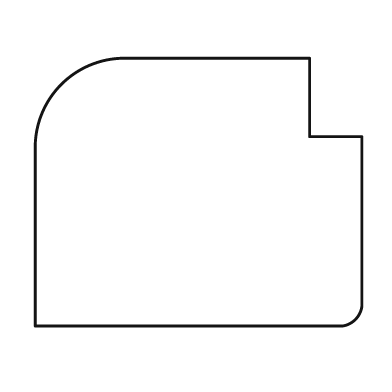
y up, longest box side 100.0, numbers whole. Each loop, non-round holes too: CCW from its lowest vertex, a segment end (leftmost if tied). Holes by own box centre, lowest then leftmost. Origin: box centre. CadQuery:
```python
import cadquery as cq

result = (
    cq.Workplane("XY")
    .moveTo(-50.0, -41.0)
    .lineTo(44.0, -41.0)
    .threePointArc((48.0, -39.0), (50.0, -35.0))
    .lineTo(50.0, 17.0)
    .lineTo(34.0, 17.0)
    .lineTo(34.0, 41.0)
    .lineTo(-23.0, 41.0)
    .threePointArc((-42.0, 33.0), (-50.0, 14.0))
    .close()
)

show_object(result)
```